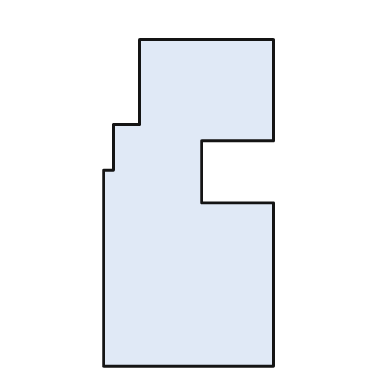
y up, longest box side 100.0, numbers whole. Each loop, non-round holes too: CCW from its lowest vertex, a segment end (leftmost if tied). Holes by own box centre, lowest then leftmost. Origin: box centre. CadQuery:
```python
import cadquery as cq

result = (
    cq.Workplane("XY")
    .moveTo(-26.0, -50.0)
    .lineTo(26.0, -50.0)
    .lineTo(26.0, 0.0)
    .lineTo(4.0, 0.0)
    .lineTo(4.0, 19.0)
    .lineTo(26.0, 19.0)
    .lineTo(26.0, 50.0)
    .lineTo(-15.0, 50.0)
    .lineTo(-15.0, 24.0)
    .lineTo(-23.0, 24.0)
    .lineTo(-23.0, 10.0)
    .lineTo(-26.0, 10.0)
    .close()
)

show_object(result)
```